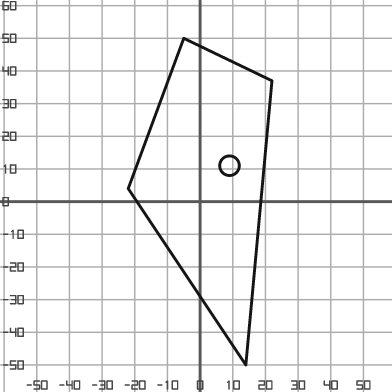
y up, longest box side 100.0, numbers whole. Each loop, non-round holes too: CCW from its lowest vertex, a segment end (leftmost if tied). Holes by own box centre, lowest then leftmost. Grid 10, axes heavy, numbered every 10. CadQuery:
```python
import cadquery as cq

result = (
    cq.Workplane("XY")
    .moveTo(14.0, -50.0)
    .lineTo(22.0, 37.0)
    .lineTo(-5.0, 50.0)
    .lineTo(-22.0, 4.0)
    .close()
    .moveTo(9.0, 11.0)
    .circle(3.0)
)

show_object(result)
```